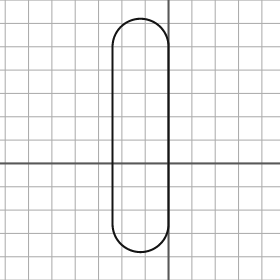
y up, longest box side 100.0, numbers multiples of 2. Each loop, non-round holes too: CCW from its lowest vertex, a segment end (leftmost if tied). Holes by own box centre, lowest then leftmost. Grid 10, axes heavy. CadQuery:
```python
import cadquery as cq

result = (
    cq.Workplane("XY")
    .moveTo(-24.0, -26.0)
    .threePointArc((-12.0, -38.0), (0.0, -26.0))
    .lineTo(0.0, 50.0)
    .threePointArc((-12.0, 62.0), (-24.0, 50.0))
    .close()
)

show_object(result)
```